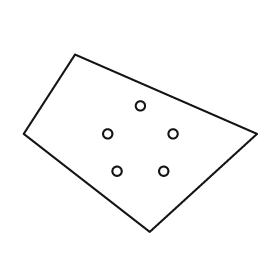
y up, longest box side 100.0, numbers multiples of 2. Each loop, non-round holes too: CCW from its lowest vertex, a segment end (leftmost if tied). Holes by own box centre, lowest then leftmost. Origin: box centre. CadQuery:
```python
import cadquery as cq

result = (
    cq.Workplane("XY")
    .moveTo(4.0, -38.0)
    .lineTo(50.0, 4.0)
    .lineTo(-28.0, 38.0)
    .lineTo(-50.0, 4.0)
    .close()
    .moveTo(-10.0, -12.0)
    .circle(2.0)
    .moveTo(10.0, -12.0)
    .circle(2.0)
    .moveTo(-14.0, 4.0)
    .circle(2.0)
    .moveTo(14.0, 4.0)
    .circle(2.0)
    .moveTo(0.0, 16.0)
    .circle(2.0)
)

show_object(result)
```